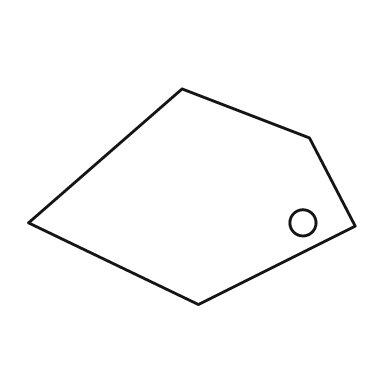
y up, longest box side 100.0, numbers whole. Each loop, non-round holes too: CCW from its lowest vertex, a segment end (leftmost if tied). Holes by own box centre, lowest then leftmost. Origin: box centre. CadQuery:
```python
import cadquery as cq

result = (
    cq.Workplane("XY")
    .moveTo(2.0, -33.0)
    .lineTo(50.0, -9.0)
    .lineTo(36.0, 18.0)
    .lineTo(-3.0, 33.0)
    .lineTo(-50.0, -8.0)
    .close()
    .moveTo(34.0, -8.0)
    .circle(4.0)
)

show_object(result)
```